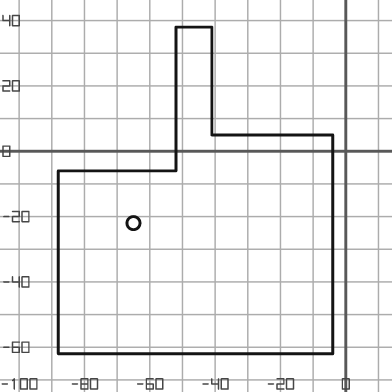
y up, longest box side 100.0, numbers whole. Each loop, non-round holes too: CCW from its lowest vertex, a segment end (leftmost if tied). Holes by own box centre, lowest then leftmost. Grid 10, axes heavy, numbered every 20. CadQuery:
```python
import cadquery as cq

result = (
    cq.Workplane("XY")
    .moveTo(-88.0, -62.0)
    .lineTo(-4.0, -62.0)
    .lineTo(-4.0, 5.0)
    .lineTo(-41.0, 5.0)
    .lineTo(-41.0, 38.0)
    .lineTo(-52.0, 38.0)
    .lineTo(-52.0, -6.0)
    .lineTo(-88.0, -6.0)
    .close()
    .moveTo(-65.0, -22.0)
    .circle(2.0)
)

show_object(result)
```